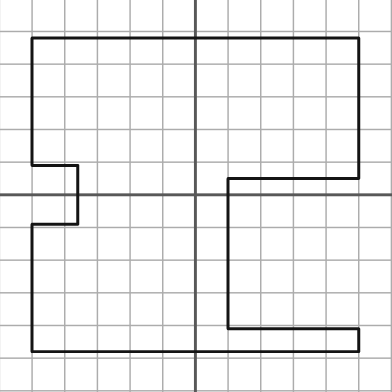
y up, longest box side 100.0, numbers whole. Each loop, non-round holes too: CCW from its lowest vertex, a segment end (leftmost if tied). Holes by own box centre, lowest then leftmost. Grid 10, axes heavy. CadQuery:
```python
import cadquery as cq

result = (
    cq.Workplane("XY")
    .moveTo(-50.0, -48.0)
    .lineTo(50.0, -48.0)
    .lineTo(50.0, -41.0)
    .lineTo(10.0, -41.0)
    .lineTo(10.0, 5.0)
    .lineTo(50.0, 5.0)
    .lineTo(50.0, 48.0)
    .lineTo(-50.0, 48.0)
    .lineTo(-50.0, 9.0)
    .lineTo(-36.0, 9.0)
    .lineTo(-36.0, -9.0)
    .lineTo(-50.0, -9.0)
    .close()
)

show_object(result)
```